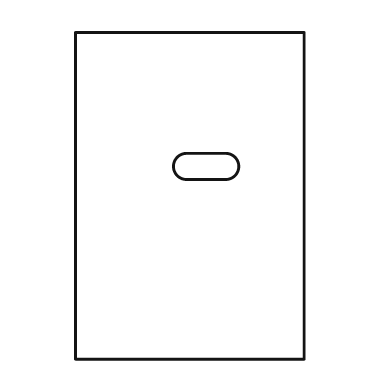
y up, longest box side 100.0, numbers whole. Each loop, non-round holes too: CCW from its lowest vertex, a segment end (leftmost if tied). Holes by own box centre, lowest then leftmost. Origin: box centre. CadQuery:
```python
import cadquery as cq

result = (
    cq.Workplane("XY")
    .moveTo(-35.0, -50.0)
    .lineTo(35.0, -50.0)
    .lineTo(35.0, 50.0)
    .lineTo(-35.0, 50.0)
    .close()
    .moveTo(-1.0, 5.0)
    .lineTo(11.0, 5.0)
    .threePointArc((15.0, 9.0), (11.0, 13.0))
    .lineTo(-1.0, 13.0)
    .threePointArc((-5.0, 9.0), (-1.0, 5.0))
    .close()
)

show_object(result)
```